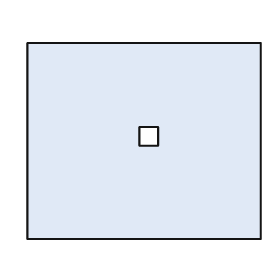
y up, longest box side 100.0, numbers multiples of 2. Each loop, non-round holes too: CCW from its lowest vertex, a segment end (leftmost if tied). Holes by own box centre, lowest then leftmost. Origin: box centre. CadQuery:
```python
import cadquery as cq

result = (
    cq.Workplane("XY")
    .moveTo(-50.0, -42.0)
    .lineTo(50.0, -42.0)
    .lineTo(50.0, 42.0)
    .lineTo(-50.0, 42.0)
    .close()
    .moveTo(-2.0, -2.0)
    .lineTo(6.0, -2.0)
    .lineTo(6.0, 6.0)
    .lineTo(-2.0, 6.0)
    .close()
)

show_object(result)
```